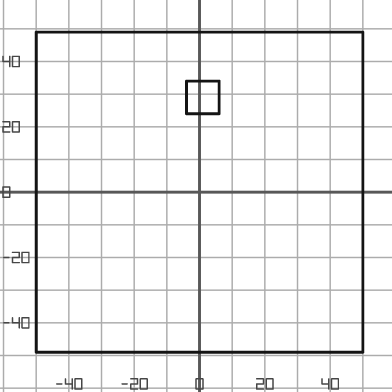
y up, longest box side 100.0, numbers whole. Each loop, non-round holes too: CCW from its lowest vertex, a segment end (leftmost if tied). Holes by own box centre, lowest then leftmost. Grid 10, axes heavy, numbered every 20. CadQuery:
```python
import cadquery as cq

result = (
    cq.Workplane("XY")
    .moveTo(-50.0, -49.0)
    .lineTo(50.0, -49.0)
    .lineTo(50.0, 49.0)
    .lineTo(-50.0, 49.0)
    .close()
    .moveTo(-4.0, 24.0)
    .lineTo(6.0, 24.0)
    .lineTo(6.0, 34.0)
    .lineTo(-4.0, 34.0)
    .close()
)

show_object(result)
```